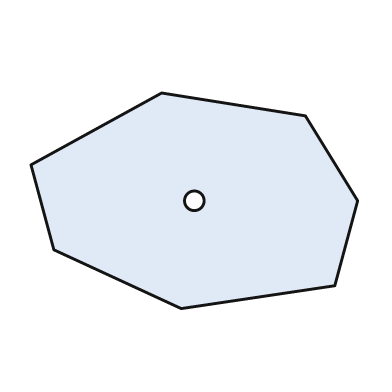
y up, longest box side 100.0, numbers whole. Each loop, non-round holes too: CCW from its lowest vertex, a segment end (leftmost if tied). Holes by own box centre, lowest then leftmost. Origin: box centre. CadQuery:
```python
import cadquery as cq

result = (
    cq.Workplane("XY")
    .moveTo(-4.0, -33.0)
    .lineTo(43.0, -26.0)
    .lineTo(50.0, 0.0)
    .lineTo(34.0, 26.0)
    .lineTo(-10.0, 33.0)
    .lineTo(-50.0, 11.0)
    .lineTo(-43.0, -15.0)
    .close()
    .moveTo(0.0, 0.0)
    .circle(3.0)
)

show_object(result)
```